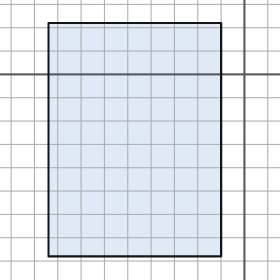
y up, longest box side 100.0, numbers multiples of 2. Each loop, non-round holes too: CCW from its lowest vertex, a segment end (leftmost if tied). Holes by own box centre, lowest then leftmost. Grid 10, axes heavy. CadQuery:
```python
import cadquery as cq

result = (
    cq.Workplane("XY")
    .moveTo(-84.0, -78.0)
    .lineTo(-10.0, -78.0)
    .lineTo(-10.0, 22.0)
    .lineTo(-84.0, 22.0)
    .close()
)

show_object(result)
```